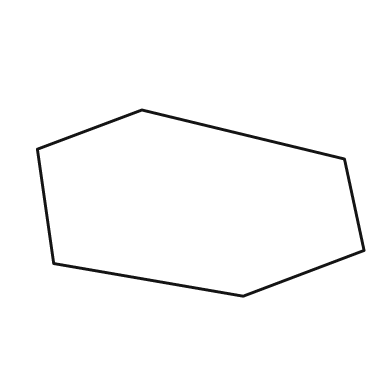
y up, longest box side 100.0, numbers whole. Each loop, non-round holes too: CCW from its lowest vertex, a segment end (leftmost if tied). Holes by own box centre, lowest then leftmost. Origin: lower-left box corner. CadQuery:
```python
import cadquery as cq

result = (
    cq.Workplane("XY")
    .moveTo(63.0, 0.0)
    .lineTo(100.0, 14.0)
    .lineTo(94.0, 42.0)
    .lineTo(32.0, 57.0)
    .lineTo(0.0, 45.0)
    .lineTo(5.0, 10.0)
    .close()
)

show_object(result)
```